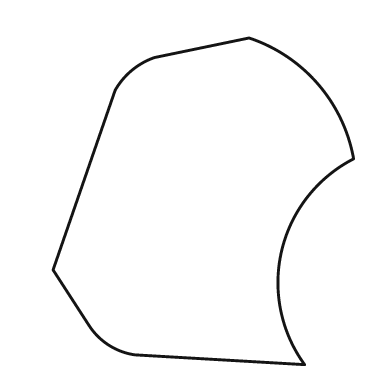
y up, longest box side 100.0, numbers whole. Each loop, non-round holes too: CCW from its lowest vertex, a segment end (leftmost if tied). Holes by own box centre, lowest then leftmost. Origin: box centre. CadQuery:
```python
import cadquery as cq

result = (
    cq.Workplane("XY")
    .moveTo(31.0, -50.0)
    .threePointArc((24.0, -15.0), (46.0, 13.0))
    .threePointArc((35.0, 36.0), (14.0, 50.0))
    .lineTo(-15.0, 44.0)
    .threePointArc((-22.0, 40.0), (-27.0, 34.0))
    .lineTo(-46.0, -21.0)
    .lineTo(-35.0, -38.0)
    .threePointArc((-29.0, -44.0), (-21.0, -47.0))
    .close()
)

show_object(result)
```